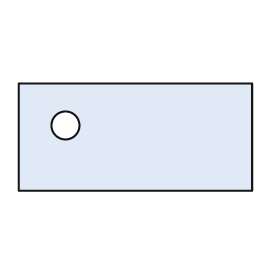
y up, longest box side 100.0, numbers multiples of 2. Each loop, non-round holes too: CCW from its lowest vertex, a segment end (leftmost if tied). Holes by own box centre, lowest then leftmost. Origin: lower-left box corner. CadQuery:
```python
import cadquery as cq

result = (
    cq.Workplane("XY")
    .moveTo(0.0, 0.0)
    .lineTo(100.0, 0.0)
    .lineTo(100.0, 46.0)
    .lineTo(0.0, 46.0)
    .close()
    .moveTo(20.0, 28.0)
    .circle(6.0)
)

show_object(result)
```